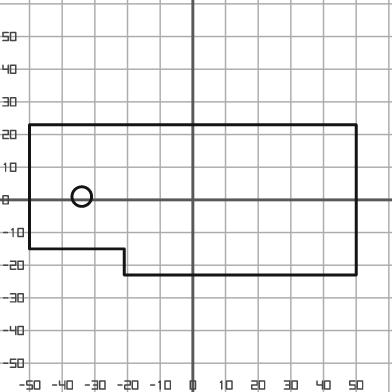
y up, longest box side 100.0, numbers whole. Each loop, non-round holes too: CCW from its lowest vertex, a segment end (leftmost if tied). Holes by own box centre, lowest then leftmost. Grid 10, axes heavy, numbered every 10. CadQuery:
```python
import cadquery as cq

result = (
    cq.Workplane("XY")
    .moveTo(-21.0, -23.0)
    .lineTo(50.0, -23.0)
    .lineTo(50.0, 23.0)
    .lineTo(-50.0, 23.0)
    .lineTo(-50.0, -15.0)
    .lineTo(-21.0, -15.0)
    .close()
    .moveTo(-34.0, 1.0)
    .circle(3.0)
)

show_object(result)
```